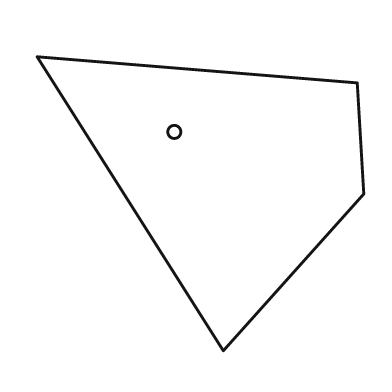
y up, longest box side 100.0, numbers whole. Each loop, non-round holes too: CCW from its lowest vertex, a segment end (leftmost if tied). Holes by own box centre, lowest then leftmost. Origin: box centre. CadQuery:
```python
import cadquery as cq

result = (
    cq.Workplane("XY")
    .moveTo(7.0, -45.0)
    .lineTo(50.0, 3.0)
    .lineTo(48.0, 37.0)
    .lineTo(-50.0, 45.0)
    .close()
    .moveTo(-8.0, 22.0)
    .circle(2.0)
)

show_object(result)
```